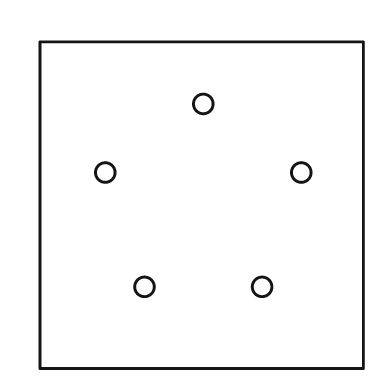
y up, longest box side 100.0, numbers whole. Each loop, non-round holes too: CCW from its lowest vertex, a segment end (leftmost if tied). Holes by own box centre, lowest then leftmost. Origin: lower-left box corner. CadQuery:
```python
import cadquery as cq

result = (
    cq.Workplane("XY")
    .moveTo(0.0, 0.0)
    .lineTo(99.0, 0.0)
    .lineTo(99.0, 100.0)
    .lineTo(0.0, 100.0)
    .close()
    .moveTo(32.0, 25.0)
    .circle(3.0)
    .moveTo(68.0, 25.0)
    .circle(3.0)
    .moveTo(20.0, 60.0)
    .circle(3.0)
    .moveTo(80.0, 60.0)
    .circle(3.0)
    .moveTo(50.0, 81.0)
    .circle(3.0)
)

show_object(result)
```